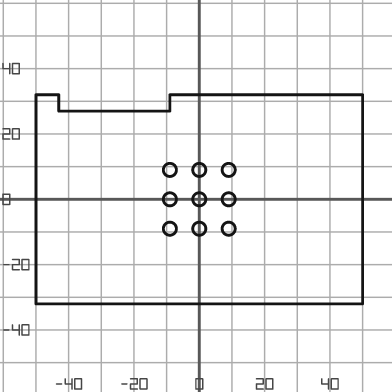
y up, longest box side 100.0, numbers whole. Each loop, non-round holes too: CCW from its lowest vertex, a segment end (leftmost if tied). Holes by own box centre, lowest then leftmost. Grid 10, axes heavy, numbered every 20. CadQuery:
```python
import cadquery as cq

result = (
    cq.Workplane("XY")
    .moveTo(-50.0, -32.0)
    .lineTo(50.0, -32.0)
    .lineTo(50.0, 32.0)
    .lineTo(-9.0, 32.0)
    .lineTo(-9.0, 27.0)
    .lineTo(-43.0, 27.0)
    .lineTo(-43.0, 32.0)
    .lineTo(-50.0, 32.0)
    .close()
    .moveTo(-9.0, -9.0)
    .circle(2.0)
    .moveTo(0.0, -9.0)
    .circle(2.0)
    .moveTo(9.0, -9.0)
    .circle(2.0)
    .moveTo(-9.0, 0.0)
    .circle(2.0)
    .moveTo(0.0, 0.0)
    .circle(2.0)
    .moveTo(9.0, 0.0)
    .circle(2.0)
    .moveTo(-9.0, 9.0)
    .circle(2.0)
    .moveTo(0.0, 9.0)
    .circle(2.0)
    .moveTo(9.0, 9.0)
    .circle(2.0)
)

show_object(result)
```